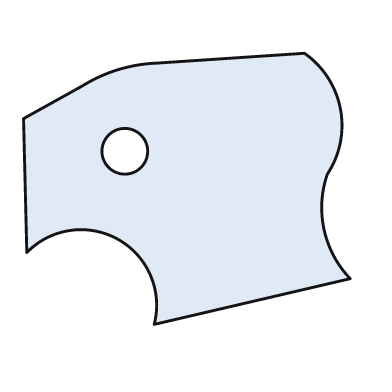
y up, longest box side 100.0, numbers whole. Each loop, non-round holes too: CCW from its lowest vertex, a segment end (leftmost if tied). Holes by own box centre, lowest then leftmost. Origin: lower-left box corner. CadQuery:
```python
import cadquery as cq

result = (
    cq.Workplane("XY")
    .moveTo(40.0, 0.0)
    .lineTo(100.0, 14.0)
    .threePointArc((92.0, 29.0), (93.0, 46.0))
    .threePointArc((97.0, 66.0), (86.0, 83.0))
    .lineTo(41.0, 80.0)
    .threePointArc((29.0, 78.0), (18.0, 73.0))
    .lineTo(0.0, 63.0)
    .lineTo(1.0, 22.0)
    .threePointArc((29.0, 26.0), (40.0, 0.0))
    .close()
    .moveTo(31.0, 53.0)
    .circle(7.0)
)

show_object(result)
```